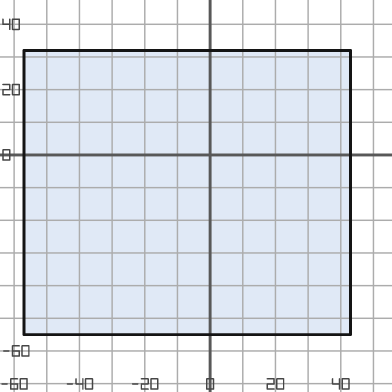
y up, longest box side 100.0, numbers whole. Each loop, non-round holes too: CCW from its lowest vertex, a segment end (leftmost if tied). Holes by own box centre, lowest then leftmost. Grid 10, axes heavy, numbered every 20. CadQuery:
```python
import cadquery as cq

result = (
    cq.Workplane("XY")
    .moveTo(-57.0, -55.0)
    .lineTo(43.0, -55.0)
    .lineTo(43.0, 32.0)
    .lineTo(-57.0, 32.0)
    .close()
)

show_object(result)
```